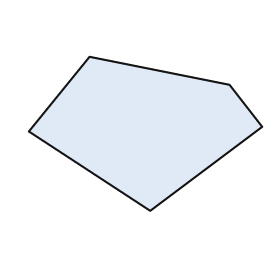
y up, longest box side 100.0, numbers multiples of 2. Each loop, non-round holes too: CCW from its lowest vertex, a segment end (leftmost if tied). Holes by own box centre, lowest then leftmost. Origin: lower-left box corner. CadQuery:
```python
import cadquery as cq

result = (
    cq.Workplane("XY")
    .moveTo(52.0, 0.0)
    .lineTo(100.0, 36.0)
    .lineTo(86.0, 54.0)
    .lineTo(26.0, 66.0)
    .lineTo(0.0, 34.0)
    .close()
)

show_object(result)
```